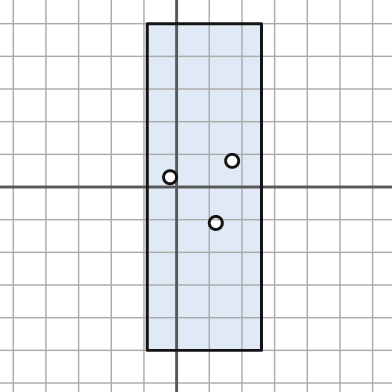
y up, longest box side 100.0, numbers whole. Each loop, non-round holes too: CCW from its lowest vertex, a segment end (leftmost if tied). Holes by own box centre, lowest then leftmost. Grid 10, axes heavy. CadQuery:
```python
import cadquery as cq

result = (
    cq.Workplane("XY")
    .moveTo(-9.0, -50.0)
    .lineTo(26.0, -50.0)
    .lineTo(26.0, 50.0)
    .lineTo(-9.0, 50.0)
    .close()
    .moveTo(12.0, -11.0)
    .circle(2.0)
    .moveTo(-2.0, 3.0)
    .circle(2.0)
    .moveTo(17.0, 8.0)
    .circle(2.0)
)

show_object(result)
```